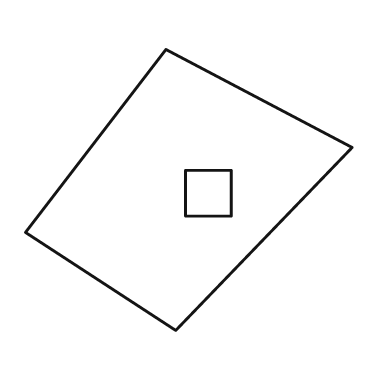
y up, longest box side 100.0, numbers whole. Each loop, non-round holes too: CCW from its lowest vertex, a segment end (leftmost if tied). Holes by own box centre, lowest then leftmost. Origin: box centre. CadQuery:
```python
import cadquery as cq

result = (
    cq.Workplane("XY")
    .moveTo(-4.0, -43.0)
    .lineTo(50.0, 13.0)
    .lineTo(-7.0, 43.0)
    .lineTo(-50.0, -13.0)
    .close()
    .moveTo(-1.0, -8.0)
    .lineTo(13.0, -8.0)
    .lineTo(13.0, 6.0)
    .lineTo(-1.0, 6.0)
    .close()
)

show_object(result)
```